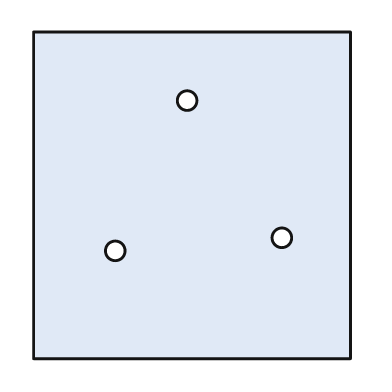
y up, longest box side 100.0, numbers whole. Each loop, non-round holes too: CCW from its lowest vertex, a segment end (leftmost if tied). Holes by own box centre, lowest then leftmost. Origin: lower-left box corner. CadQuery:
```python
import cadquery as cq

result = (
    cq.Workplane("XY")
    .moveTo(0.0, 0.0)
    .lineTo(97.0, 0.0)
    .lineTo(97.0, 100.0)
    .lineTo(0.0, 100.0)
    .close()
    .moveTo(25.0, 33.0)
    .circle(3.0)
    .moveTo(76.0, 37.0)
    .circle(3.0)
    .moveTo(47.0, 79.0)
    .circle(3.0)
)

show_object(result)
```